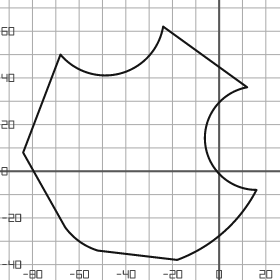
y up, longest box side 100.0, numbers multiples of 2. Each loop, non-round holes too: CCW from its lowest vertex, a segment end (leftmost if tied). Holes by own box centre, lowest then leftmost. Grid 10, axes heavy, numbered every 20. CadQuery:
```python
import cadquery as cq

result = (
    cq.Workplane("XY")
    .moveTo(-18.0, -38.0)
    .threePointArc((2.0, -26.0), (16.0, -8.0))
    .threePointArc((-6.0, 12.0), (12.0, 36.0))
    .lineTo(-24.0, 62.0)
    .threePointArc((-42.0, 42.0), (-68.0, 50.0))
    .lineTo(-84.0, 8.0)
    .lineTo(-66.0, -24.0)
    .threePointArc((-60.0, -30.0), (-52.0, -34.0))
    .close()
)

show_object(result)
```